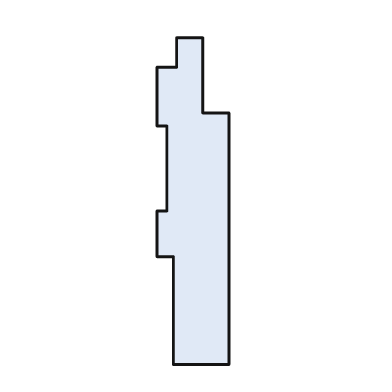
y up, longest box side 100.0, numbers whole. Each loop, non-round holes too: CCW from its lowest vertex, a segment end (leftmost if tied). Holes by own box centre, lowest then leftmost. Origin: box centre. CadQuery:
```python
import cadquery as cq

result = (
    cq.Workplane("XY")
    .moveTo(-6.0, -50.0)
    .lineTo(11.0, -50.0)
    .lineTo(11.0, 27.0)
    .lineTo(3.0, 27.0)
    .lineTo(3.0, 50.0)
    .lineTo(-5.0, 50.0)
    .lineTo(-5.0, 41.0)
    .lineTo(-11.0, 41.0)
    .lineTo(-11.0, 23.0)
    .lineTo(-8.0, 23.0)
    .lineTo(-8.0, -3.0)
    .lineTo(-11.0, -3.0)
    .lineTo(-11.0, -17.0)
    .lineTo(-6.0, -17.0)
    .close()
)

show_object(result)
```